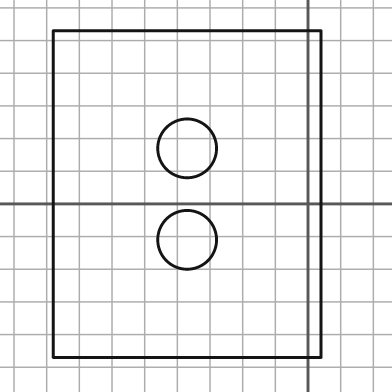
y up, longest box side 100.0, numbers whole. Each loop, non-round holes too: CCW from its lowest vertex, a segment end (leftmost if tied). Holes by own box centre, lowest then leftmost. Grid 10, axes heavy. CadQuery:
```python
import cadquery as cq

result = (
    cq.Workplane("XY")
    .moveTo(-78.0, -47.0)
    .lineTo(4.0, -47.0)
    .lineTo(4.0, 53.0)
    .lineTo(-78.0, 53.0)
    .close()
    .moveTo(-37.0, -11.0)
    .circle(9.0)
    .moveTo(-37.0, 17.0)
    .circle(9.0)
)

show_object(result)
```